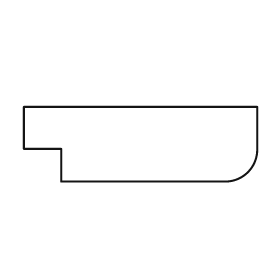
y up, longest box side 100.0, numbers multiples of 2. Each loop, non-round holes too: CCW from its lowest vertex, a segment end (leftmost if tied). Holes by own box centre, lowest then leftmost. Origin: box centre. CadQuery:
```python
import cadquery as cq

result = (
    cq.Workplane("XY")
    .moveTo(-34.0, -16.0)
    .lineTo(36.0, -16.0)
    .threePointArc((46.0, -12.0), (50.0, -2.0))
    .lineTo(50.0, 16.0)
    .lineTo(-50.0, 16.0)
    .lineTo(-50.0, -2.0)
    .lineTo(-34.0, -2.0)
    .close()
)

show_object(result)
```